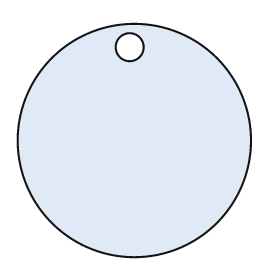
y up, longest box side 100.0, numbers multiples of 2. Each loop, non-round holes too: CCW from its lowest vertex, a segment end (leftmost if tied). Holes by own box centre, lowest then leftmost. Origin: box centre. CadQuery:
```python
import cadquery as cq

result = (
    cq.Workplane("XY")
    .moveTo(0.0, 0.0)
    .circle(50.0)
    .moveTo(-2.0, 40.0)
    .circle(6.0)
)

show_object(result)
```